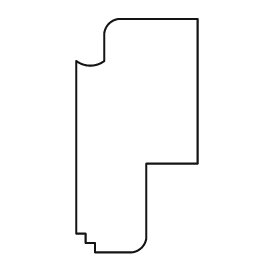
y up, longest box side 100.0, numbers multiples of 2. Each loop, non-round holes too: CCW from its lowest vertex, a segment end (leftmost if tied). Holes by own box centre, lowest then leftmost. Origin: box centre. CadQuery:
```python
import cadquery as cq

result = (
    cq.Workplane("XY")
    .moveTo(-18.0, -50.0)
    .lineTo(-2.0, -50.0)
    .threePointArc((2.0, -48.0), (4.0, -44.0))
    .lineTo(4.0, -12.0)
    .lineTo(26.0, -12.0)
    .lineTo(26.0, 50.0)
    .lineTo(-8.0, 50.0)
    .threePointArc((-12.0, 48.0), (-14.0, 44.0))
    .lineTo(-14.0, 32.0)
    .threePointArc((-20.0, 30.0), (-26.0, 32.0))
    .lineTo(-26.0, -42.0)
    .lineTo(-22.0, -42.0)
    .lineTo(-22.0, -46.0)
    .lineTo(-18.0, -46.0)
    .close()
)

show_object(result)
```